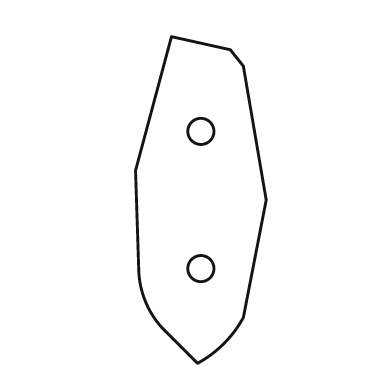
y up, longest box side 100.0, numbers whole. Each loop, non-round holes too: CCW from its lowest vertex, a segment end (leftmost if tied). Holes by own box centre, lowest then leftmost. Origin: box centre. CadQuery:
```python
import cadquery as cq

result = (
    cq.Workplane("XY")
    .moveTo(-1.0, -50.0)
    .threePointArc((7.0, -44.0), (13.0, -36.0))
    .lineTo(20.0, 0.0)
    .lineTo(13.0, 41.0)
    .lineTo(9.0, 46.0)
    .lineTo(-9.0, 50.0)
    .lineTo(-20.0, 9.0)
    .lineTo(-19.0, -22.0)
    .threePointArc((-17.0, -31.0), (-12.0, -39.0))
    .close()
    .moveTo(0.0, -21.0)
    .circle(4.0)
    .moveTo(0.0, 21.0)
    .circle(4.0)
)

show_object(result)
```